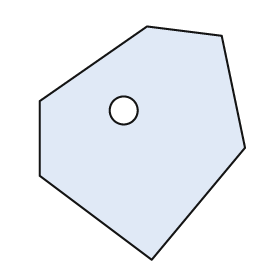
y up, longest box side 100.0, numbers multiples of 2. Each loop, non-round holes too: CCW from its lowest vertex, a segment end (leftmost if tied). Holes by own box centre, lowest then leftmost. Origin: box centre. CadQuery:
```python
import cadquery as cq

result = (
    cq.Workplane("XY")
    .moveTo(4.0, -50.0)
    .lineTo(44.0, -2.0)
    .lineTo(34.0, 46.0)
    .lineTo(2.0, 50.0)
    .lineTo(-44.0, 18.0)
    .lineTo(-44.0, -14.0)
    .close()
    .moveTo(-8.0, 14.0)
    .circle(6.0)
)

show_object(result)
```